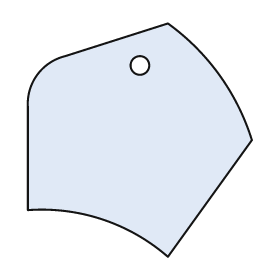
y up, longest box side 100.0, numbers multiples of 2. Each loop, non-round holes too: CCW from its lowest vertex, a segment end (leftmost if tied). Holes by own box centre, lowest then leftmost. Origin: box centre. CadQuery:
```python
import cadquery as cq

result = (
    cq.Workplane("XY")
    .moveTo(12.0, -50.0)
    .lineTo(48.0, 0.0)
    .threePointArc((34.0, 28.0), (12.0, 50.0))
    .lineTo(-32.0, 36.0)
    .threePointArc((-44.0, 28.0), (-48.0, 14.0))
    .lineTo(-48.0, -30.0)
    .threePointArc((-16.0, -34.0), (12.0, -50.0))
    .close()
    .moveTo(0.0, 32.0)
    .circle(4.0)
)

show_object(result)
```